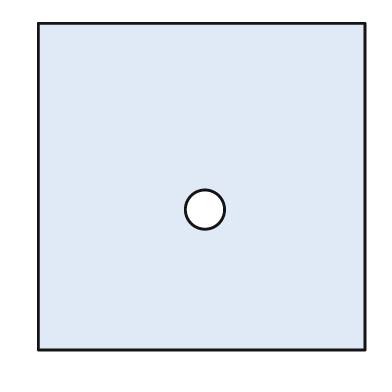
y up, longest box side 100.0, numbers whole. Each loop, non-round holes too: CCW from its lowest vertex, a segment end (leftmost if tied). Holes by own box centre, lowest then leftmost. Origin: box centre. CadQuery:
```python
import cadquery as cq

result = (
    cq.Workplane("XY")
    .moveTo(-50.0, -50.0)
    .lineTo(50.0, -50.0)
    .lineTo(50.0, 50.0)
    .lineTo(-50.0, 50.0)
    .close()
    .moveTo(1.0, -7.0)
    .circle(6.0)
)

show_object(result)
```